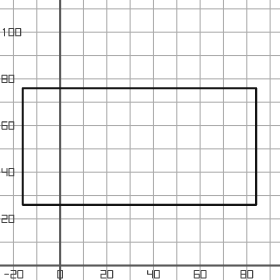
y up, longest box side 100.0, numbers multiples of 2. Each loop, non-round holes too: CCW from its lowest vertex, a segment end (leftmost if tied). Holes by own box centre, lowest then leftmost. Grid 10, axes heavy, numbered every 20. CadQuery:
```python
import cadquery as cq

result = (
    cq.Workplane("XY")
    .moveTo(-16.0, 26.0)
    .lineTo(84.0, 26.0)
    .lineTo(84.0, 76.0)
    .lineTo(-16.0, 76.0)
    .close()
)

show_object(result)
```